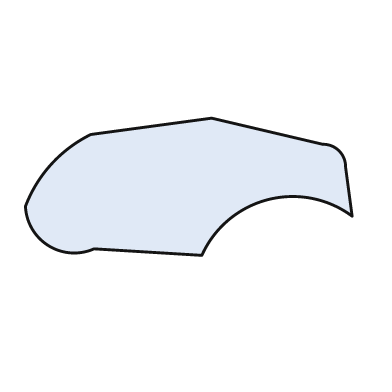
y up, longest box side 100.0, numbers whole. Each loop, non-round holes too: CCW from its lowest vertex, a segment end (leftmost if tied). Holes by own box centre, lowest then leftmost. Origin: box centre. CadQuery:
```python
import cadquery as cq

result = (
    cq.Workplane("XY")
    .moveTo(4.0, -21.0)
    .threePointArc((24.0, -4.0), (50.0, -9.0))
    .lineTo(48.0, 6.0)
    .threePointArc((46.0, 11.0), (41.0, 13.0))
    .lineTo(7.0, 21.0)
    .lineTo(-30.0, 16.0)
    .threePointArc((-42.0, 7.0), (-50.0, -6.0))
    .threePointArc((-43.0, -18.0), (-29.0, -19.0))
    .close()
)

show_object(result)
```